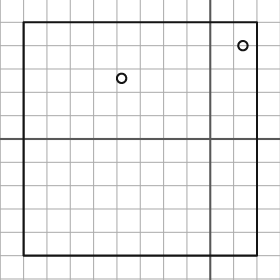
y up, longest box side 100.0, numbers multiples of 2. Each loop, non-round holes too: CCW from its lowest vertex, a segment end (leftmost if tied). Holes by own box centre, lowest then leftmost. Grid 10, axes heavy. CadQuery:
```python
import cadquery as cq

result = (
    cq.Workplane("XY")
    .moveTo(-80.0, -50.0)
    .lineTo(20.0, -50.0)
    .lineTo(20.0, 50.0)
    .lineTo(-80.0, 50.0)
    .close()
    .moveTo(-38.0, 26.0)
    .circle(2.0)
    .moveTo(14.0, 40.0)
    .circle(2.0)
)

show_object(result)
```